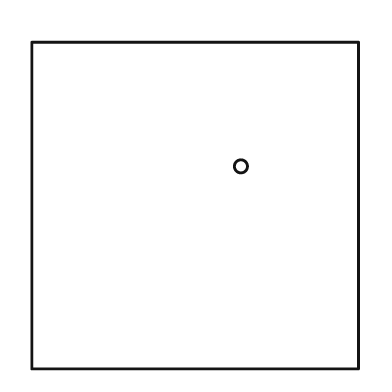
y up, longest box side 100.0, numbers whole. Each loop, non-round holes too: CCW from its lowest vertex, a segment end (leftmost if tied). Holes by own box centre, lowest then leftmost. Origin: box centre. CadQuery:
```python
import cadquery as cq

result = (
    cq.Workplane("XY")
    .moveTo(-50.0, -50.0)
    .lineTo(50.0, -50.0)
    .lineTo(50.0, 50.0)
    .lineTo(-50.0, 50.0)
    .close()
    .moveTo(14.0, 12.0)
    .circle(2.0)
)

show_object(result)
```